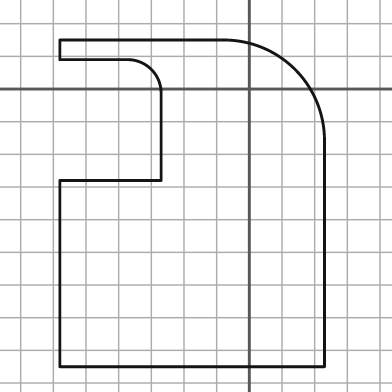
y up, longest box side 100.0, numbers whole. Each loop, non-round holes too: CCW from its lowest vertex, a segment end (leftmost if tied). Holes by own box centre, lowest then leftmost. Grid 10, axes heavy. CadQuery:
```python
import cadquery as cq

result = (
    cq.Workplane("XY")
    .moveTo(-58.0, -85.0)
    .lineTo(23.0, -85.0)
    .lineTo(23.0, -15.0)
    .threePointArc((14.0, 6.0), (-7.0, 15.0))
    .lineTo(-58.0, 15.0)
    .lineTo(-58.0, 9.0)
    .lineTo(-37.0, 9.0)
    .threePointArc((-30.0, 6.0), (-27.0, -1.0))
    .lineTo(-27.0, -28.0)
    .lineTo(-58.0, -28.0)
    .close()
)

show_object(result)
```